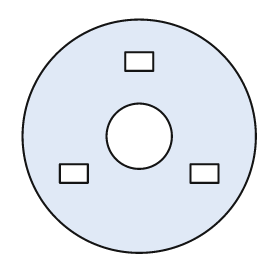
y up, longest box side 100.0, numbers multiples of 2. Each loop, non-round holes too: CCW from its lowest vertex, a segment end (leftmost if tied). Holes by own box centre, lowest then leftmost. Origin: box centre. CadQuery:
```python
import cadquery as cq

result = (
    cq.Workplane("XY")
    .moveTo(0.0, 0.0)
    .circle(50.0)
    .moveTo(-34.0, -20.0)
    .lineTo(-22.0, -20.0)
    .lineTo(-22.0, -12.0)
    .lineTo(-34.0, -12.0)
    .close()
    .moveTo(22.0, -20.0)
    .lineTo(34.0, -20.0)
    .lineTo(34.0, -12.0)
    .lineTo(22.0, -12.0)
    .close()
    .moveTo(0.0, 0.0)
    .circle(14.0)
    .moveTo(-6.0, 28.0)
    .lineTo(6.0, 28.0)
    .lineTo(6.0, 36.0)
    .lineTo(-6.0, 36.0)
    .close()
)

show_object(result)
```